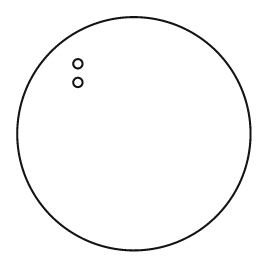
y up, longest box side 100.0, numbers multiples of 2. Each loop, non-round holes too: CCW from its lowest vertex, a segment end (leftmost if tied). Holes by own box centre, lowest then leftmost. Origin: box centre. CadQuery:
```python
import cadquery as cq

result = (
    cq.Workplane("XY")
    .moveTo(0.0, 0.0)
    .circle(50.0)
    .moveTo(-24.0, 22.0)
    .circle(2.0)
    .moveTo(-24.0, 30.0)
    .circle(2.0)
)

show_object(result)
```